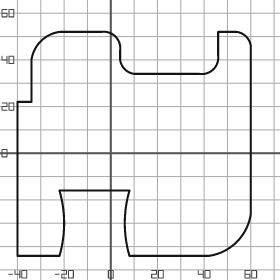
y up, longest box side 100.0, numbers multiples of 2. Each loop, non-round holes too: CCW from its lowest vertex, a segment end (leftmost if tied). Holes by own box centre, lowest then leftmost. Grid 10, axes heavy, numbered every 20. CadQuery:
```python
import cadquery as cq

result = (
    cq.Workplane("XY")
    .moveTo(-40.0, -44.0)
    .lineTo(-22.0, -44.0)
    .threePointArc((-20.0, -30.0), (-22.0, -16.0))
    .lineTo(8.0, -16.0)
    .threePointArc((6.0, -30.0), (8.0, -44.0))
    .lineTo(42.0, -44.0)
    .threePointArc((54.0, -38.0), (60.0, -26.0))
    .lineTo(60.0, 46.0)
    .threePointArc((58.0, 50.0), (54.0, 52.0))
    .lineTo(46.0, 52.0)
    .lineTo(46.0, 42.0)
    .threePointArc((44.0, 36.0), (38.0, 34.0))
    .lineTo(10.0, 34.0)
    .threePointArc((6.0, 36.0), (4.0, 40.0))
    .lineTo(4.0, 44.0)
    .threePointArc((2.0, 50.0), (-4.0, 52.0))
    .lineTo(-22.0, 52.0)
    .threePointArc((-30.0, 48.0), (-34.0, 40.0))
    .lineTo(-34.0, 22.0)
    .lineTo(-40.0, 22.0)
    .close()
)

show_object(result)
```